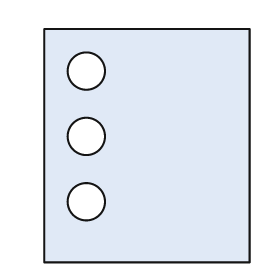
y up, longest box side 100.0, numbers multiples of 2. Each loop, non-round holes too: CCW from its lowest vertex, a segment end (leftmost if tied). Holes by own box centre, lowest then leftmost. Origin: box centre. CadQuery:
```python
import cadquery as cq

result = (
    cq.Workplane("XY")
    .moveTo(-44.0, -50.0)
    .lineTo(44.0, -50.0)
    .lineTo(44.0, 50.0)
    .lineTo(-44.0, 50.0)
    .close()
    .moveTo(-26.0, -24.0)
    .circle(8.0)
    .moveTo(-26.0, 4.0)
    .circle(8.0)
    .moveTo(-26.0, 32.0)
    .circle(8.0)
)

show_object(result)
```